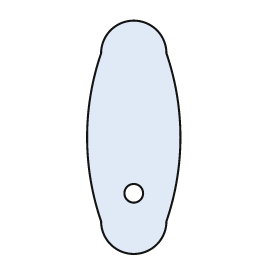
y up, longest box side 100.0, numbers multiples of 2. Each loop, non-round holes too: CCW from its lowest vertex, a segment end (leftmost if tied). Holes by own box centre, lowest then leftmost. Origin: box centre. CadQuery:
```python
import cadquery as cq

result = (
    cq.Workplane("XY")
    .moveTo(-14.0, -36.0)
    .threePointArc((0.0, -50.0), (14.0, -36.0))
    .threePointArc((20.0, 0.0), (14.0, 36.0))
    .threePointArc((0.0, 50.0), (-14.0, 36.0))
    .threePointArc((-20.0, 0.0), (-14.0, -36.0))
    .close()
    .moveTo(0.0, -24.0)
    .circle(4.0)
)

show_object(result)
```